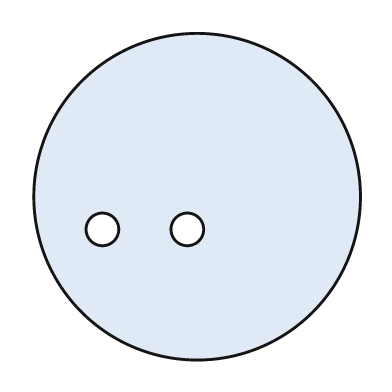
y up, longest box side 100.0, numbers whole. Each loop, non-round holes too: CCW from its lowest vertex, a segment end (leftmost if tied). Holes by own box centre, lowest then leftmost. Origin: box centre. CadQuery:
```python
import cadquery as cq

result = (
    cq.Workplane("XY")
    .moveTo(0.0, 0.0)
    .circle(50.0)
    .moveTo(-29.0, -10.0)
    .circle(5.0)
    .moveTo(-3.0, -10.0)
    .circle(5.0)
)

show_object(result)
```